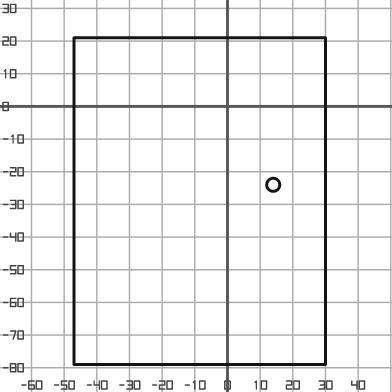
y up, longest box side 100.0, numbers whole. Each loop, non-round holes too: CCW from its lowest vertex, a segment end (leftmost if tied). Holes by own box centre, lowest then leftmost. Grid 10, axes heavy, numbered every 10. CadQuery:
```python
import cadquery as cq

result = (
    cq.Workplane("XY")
    .moveTo(-47.0, -79.0)
    .lineTo(30.0, -79.0)
    .lineTo(30.0, 21.0)
    .lineTo(-47.0, 21.0)
    .close()
    .moveTo(14.0, -24.0)
    .circle(2.0)
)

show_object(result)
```